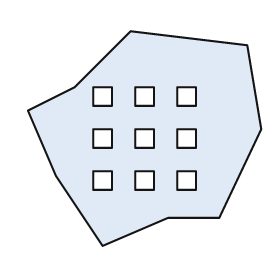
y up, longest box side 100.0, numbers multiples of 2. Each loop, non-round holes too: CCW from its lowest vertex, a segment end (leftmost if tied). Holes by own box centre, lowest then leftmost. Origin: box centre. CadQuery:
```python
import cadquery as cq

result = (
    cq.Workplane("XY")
    .moveTo(-18.0, -46.0)
    .lineTo(10.0, -34.0)
    .lineTo(32.0, -34.0)
    .lineTo(50.0, 4.0)
    .lineTo(44.0, 40.0)
    .lineTo(-6.0, 46.0)
    .lineTo(-30.0, 22.0)
    .lineTo(-50.0, 12.0)
    .lineTo(-38.0, -16.0)
    .close()
    .moveTo(-22.0, -22.0)
    .lineTo(-14.0, -22.0)
    .lineTo(-14.0, -14.0)
    .lineTo(-22.0, -14.0)
    .close()
    .moveTo(-4.0, -22.0)
    .lineTo(4.0, -22.0)
    .lineTo(4.0, -14.0)
    .lineTo(-4.0, -14.0)
    .close()
    .moveTo(14.0, -22.0)
    .lineTo(22.0, -22.0)
    .lineTo(22.0, -14.0)
    .lineTo(14.0, -14.0)
    .close()
    .moveTo(-22.0, -4.0)
    .lineTo(-14.0, -4.0)
    .lineTo(-14.0, 4.0)
    .lineTo(-22.0, 4.0)
    .close()
    .moveTo(-4.0, -4.0)
    .lineTo(4.0, -4.0)
    .lineTo(4.0, 4.0)
    .lineTo(-4.0, 4.0)
    .close()
    .moveTo(14.0, -4.0)
    .lineTo(22.0, -4.0)
    .lineTo(22.0, 4.0)
    .lineTo(14.0, 4.0)
    .close()
    .moveTo(-22.0, 14.0)
    .lineTo(-14.0, 14.0)
    .lineTo(-14.0, 22.0)
    .lineTo(-22.0, 22.0)
    .close()
    .moveTo(-4.0, 14.0)
    .lineTo(4.0, 14.0)
    .lineTo(4.0, 22.0)
    .lineTo(-4.0, 22.0)
    .close()
    .moveTo(14.0, 14.0)
    .lineTo(22.0, 14.0)
    .lineTo(22.0, 22.0)
    .lineTo(14.0, 22.0)
    .close()
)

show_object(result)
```